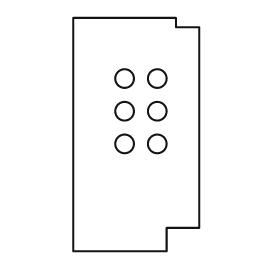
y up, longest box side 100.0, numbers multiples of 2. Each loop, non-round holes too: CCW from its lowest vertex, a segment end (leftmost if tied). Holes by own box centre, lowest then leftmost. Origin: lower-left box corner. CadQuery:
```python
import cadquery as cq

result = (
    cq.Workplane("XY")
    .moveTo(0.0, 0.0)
    .lineTo(40.0, 0.0)
    .lineTo(40.0, 10.0)
    .lineTo(54.0, 10.0)
    .lineTo(54.0, 96.0)
    .lineTo(44.0, 96.0)
    .lineTo(44.0, 100.0)
    .lineTo(0.0, 100.0)
    .close()
    .moveTo(22.0, 46.0)
    .circle(4.0)
    .moveTo(36.0, 46.0)
    .circle(4.0)
    .moveTo(22.0, 60.0)
    .circle(4.0)
    .moveTo(36.0, 60.0)
    .circle(4.0)
    .moveTo(22.0, 74.0)
    .circle(4.0)
    .moveTo(36.0, 74.0)
    .circle(4.0)
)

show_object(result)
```